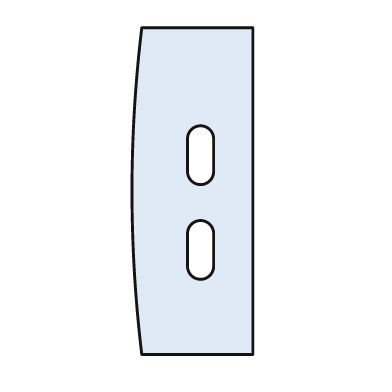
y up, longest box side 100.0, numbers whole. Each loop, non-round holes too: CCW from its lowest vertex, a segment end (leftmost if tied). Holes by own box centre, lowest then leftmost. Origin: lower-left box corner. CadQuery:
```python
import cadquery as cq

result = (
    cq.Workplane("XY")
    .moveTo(3.0, 0.0)
    .lineTo(37.0, 0.0)
    .lineTo(37.0, 100.0)
    .lineTo(3.0, 100.0)
    .threePointArc((0.0, 50.0), (3.0, 0.0))
    .close()
    .moveTo(17.0, 27.0)
    .threePointArc((21.0, 23.0), (25.0, 27.0))
    .lineTo(25.0, 37.0)
    .threePointArc((21.0, 41.0), (17.0, 37.0))
    .close()
    .moveTo(17.0, 56.0)
    .threePointArc((21.0, 52.0), (25.0, 56.0))
    .lineTo(25.0, 66.0)
    .threePointArc((21.0, 70.0), (17.0, 66.0))
    .close()
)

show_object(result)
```